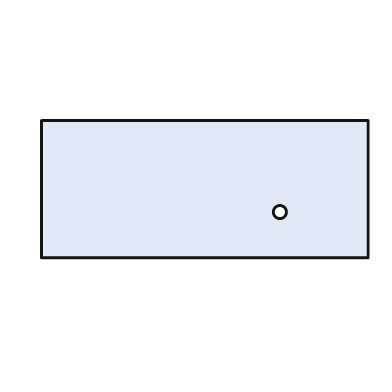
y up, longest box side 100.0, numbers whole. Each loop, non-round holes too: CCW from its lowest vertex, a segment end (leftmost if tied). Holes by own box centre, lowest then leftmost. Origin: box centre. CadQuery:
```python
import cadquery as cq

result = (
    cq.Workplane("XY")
    .moveTo(-50.0, -21.0)
    .lineTo(50.0, -21.0)
    .lineTo(50.0, 21.0)
    .lineTo(-50.0, 21.0)
    .close()
    .moveTo(23.0, -7.0)
    .circle(2.0)
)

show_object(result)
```